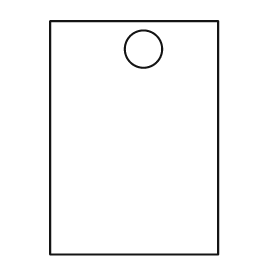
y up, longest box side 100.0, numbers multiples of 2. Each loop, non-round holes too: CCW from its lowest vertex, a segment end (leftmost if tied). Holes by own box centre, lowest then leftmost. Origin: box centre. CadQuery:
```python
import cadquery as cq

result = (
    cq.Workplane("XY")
    .moveTo(-36.0, -50.0)
    .lineTo(36.0, -50.0)
    .lineTo(36.0, 50.0)
    .lineTo(-36.0, 50.0)
    .close()
    .moveTo(4.0, 38.0)
    .circle(8.0)
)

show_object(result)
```